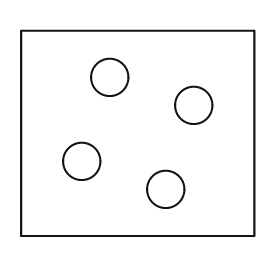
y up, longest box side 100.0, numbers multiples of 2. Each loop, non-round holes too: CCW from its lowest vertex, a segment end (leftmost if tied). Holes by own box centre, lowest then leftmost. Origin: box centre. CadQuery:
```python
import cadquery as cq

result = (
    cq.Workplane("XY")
    .moveTo(-50.0, -44.0)
    .lineTo(50.0, -44.0)
    .lineTo(50.0, 44.0)
    .lineTo(-50.0, 44.0)
    .close()
    .moveTo(12.0, -24.0)
    .circle(8.0)
    .moveTo(-24.0, -12.0)
    .circle(8.0)
    .moveTo(24.0, 12.0)
    .circle(8.0)
    .moveTo(-12.0, 24.0)
    .circle(8.0)
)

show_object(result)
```